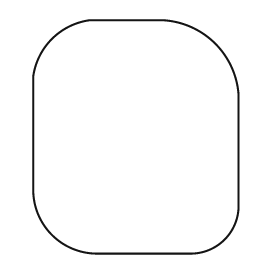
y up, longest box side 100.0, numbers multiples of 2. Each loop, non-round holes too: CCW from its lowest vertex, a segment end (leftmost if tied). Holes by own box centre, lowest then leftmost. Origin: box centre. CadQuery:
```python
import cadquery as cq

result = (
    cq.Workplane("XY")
    .moveTo(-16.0, -50.0)
    .lineTo(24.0, -50.0)
    .threePointArc((38.0, -44.0), (44.0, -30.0))
    .lineTo(44.0, 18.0)
    .threePointArc((34.0, 40.0), (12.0, 50.0))
    .lineTo(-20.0, 50.0)
    .threePointArc((-36.0, 42.0), (-44.0, 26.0))
    .lineTo(-44.0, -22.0)
    .threePointArc((-36.0, -42.0), (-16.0, -50.0))
    .close()
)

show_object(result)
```